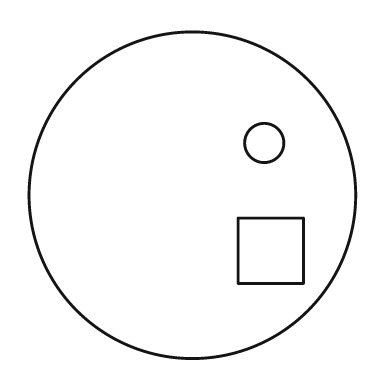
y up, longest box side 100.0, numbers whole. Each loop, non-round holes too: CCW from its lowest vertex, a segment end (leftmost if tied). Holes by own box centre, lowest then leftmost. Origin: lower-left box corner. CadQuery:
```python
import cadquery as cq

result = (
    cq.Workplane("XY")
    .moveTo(50.0, 50.0)
    .circle(50.0)
    .moveTo(64.0, 23.0)
    .lineTo(84.0, 23.0)
    .lineTo(84.0, 43.0)
    .lineTo(64.0, 43.0)
    .close()
    .moveTo(72.0, 66.0)
    .circle(6.0)
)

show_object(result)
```